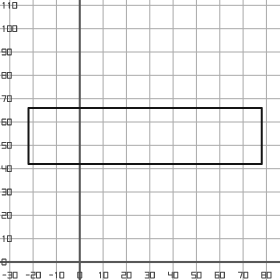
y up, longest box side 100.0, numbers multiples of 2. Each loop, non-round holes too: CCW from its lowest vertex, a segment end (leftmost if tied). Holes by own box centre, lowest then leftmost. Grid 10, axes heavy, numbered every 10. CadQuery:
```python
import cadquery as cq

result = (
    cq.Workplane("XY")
    .moveTo(-22.0, 42.0)
    .lineTo(78.0, 42.0)
    .lineTo(78.0, 66.0)
    .lineTo(-22.0, 66.0)
    .close()
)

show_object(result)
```